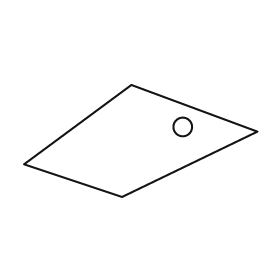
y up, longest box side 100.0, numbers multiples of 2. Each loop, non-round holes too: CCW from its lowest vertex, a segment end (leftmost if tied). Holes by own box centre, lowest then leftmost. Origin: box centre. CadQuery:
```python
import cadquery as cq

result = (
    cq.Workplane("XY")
    .moveTo(-8.0, -24.0)
    .lineTo(50.0, 4.0)
    .lineTo(-4.0, 24.0)
    .lineTo(-50.0, -10.0)
    .close()
    .moveTo(18.0, 6.0)
    .circle(4.0)
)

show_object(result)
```